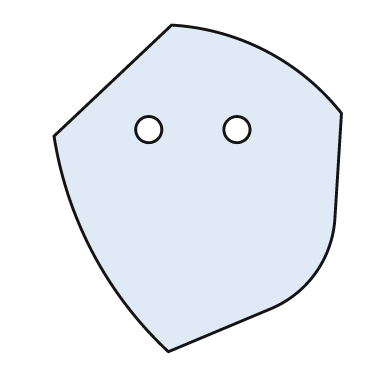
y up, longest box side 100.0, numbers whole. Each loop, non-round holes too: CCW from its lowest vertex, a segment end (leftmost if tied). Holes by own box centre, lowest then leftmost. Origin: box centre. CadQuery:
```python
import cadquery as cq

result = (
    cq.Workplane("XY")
    .moveTo(-9.0, -50.0)
    .lineTo(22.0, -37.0)
    .threePointArc((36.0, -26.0), (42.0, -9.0))
    .lineTo(44.0, 23.0)
    .threePointArc((21.0, 42.0), (-8.0, 50.0))
    .lineTo(-44.0, 16.0)
    .threePointArc((-32.0, -20.0), (-9.0, -50.0))
    .close()
    .moveTo(-15.0, 18.0)
    .circle(4.0)
    .moveTo(12.0, 18.0)
    .circle(4.0)
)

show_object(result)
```